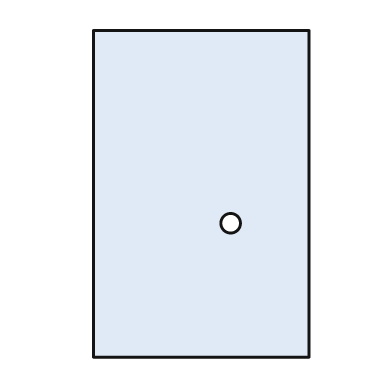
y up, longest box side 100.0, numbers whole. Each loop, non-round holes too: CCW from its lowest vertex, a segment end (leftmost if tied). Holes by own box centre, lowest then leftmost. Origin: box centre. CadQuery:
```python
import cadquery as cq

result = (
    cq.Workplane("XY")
    .moveTo(-33.0, -50.0)
    .lineTo(33.0, -50.0)
    .lineTo(33.0, 50.0)
    .lineTo(-33.0, 50.0)
    .close()
    .moveTo(9.0, -9.0)
    .circle(3.0)
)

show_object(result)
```